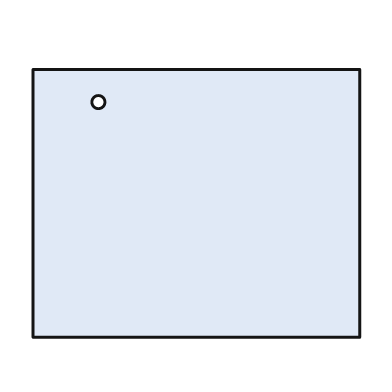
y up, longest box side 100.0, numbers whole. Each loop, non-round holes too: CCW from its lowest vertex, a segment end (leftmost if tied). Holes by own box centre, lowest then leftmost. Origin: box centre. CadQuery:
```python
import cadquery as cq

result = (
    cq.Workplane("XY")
    .moveTo(-50.0, -41.0)
    .lineTo(50.0, -41.0)
    .lineTo(50.0, 41.0)
    .lineTo(-50.0, 41.0)
    .close()
    .moveTo(-30.0, 31.0)
    .circle(2.0)
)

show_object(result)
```